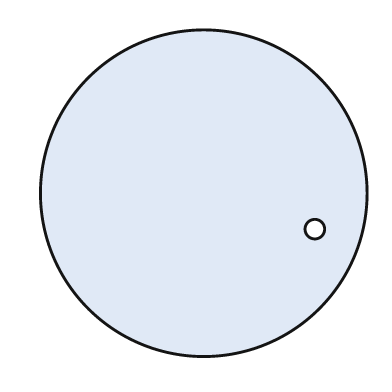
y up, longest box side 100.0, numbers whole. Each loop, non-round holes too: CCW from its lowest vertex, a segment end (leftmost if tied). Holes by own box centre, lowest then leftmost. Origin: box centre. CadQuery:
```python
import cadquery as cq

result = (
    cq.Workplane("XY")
    .moveTo(0.0, 0.0)
    .circle(50.0)
    .moveTo(34.0, -11.0)
    .circle(3.0)
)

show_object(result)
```